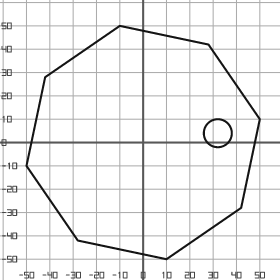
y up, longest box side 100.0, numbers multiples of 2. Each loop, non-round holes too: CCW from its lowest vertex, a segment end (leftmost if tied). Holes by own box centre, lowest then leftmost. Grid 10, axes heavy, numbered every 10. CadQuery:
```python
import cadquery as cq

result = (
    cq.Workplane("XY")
    .moveTo(10.0, -50.0)
    .lineTo(42.0, -28.0)
    .lineTo(50.0, 10.0)
    .lineTo(28.0, 42.0)
    .lineTo(-10.0, 50.0)
    .lineTo(-42.0, 28.0)
    .lineTo(-50.0, -10.0)
    .lineTo(-28.0, -42.0)
    .close()
    .moveTo(32.0, 4.0)
    .circle(6.0)
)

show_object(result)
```